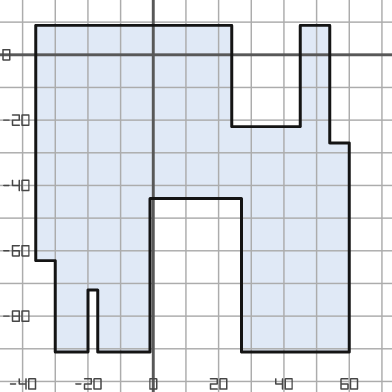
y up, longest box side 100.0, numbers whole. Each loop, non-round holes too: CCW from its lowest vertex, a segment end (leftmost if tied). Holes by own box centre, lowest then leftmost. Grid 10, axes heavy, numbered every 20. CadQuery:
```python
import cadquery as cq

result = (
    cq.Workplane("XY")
    .moveTo(-30.0, -91.0)
    .lineTo(-20.0, -91.0)
    .lineTo(-20.0, -72.0)
    .lineTo(-17.0, -72.0)
    .lineTo(-17.0, -91.0)
    .lineTo(-1.0, -91.0)
    .lineTo(-1.0, -44.0)
    .lineTo(27.0, -44.0)
    .lineTo(27.0, -91.0)
    .lineTo(60.0, -91.0)
    .lineTo(60.0, -27.0)
    .lineTo(54.0, -27.0)
    .lineTo(54.0, 9.0)
    .lineTo(45.0, 9.0)
    .lineTo(45.0, -22.0)
    .lineTo(24.0, -22.0)
    .lineTo(24.0, 9.0)
    .lineTo(-36.0, 9.0)
    .lineTo(-36.0, -63.0)
    .lineTo(-30.0, -63.0)
    .close()
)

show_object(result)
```